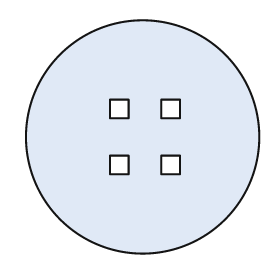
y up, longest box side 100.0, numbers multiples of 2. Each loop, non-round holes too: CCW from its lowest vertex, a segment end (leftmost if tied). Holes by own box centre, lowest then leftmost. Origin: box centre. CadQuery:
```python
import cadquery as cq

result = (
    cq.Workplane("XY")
    .moveTo(0.0, 0.0)
    .circle(50.0)
    .moveTo(-14.0, -16.0)
    .lineTo(-6.0, -16.0)
    .lineTo(-6.0, -8.0)
    .lineTo(-14.0, -8.0)
    .close()
    .moveTo(8.0, -16.0)
    .lineTo(16.0, -16.0)
    .lineTo(16.0, -8.0)
    .lineTo(8.0, -8.0)
    .close()
    .moveTo(-14.0, 8.0)
    .lineTo(-6.0, 8.0)
    .lineTo(-6.0, 16.0)
    .lineTo(-14.0, 16.0)
    .close()
    .moveTo(8.0, 8.0)
    .lineTo(16.0, 8.0)
    .lineTo(16.0, 16.0)
    .lineTo(8.0, 16.0)
    .close()
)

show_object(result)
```